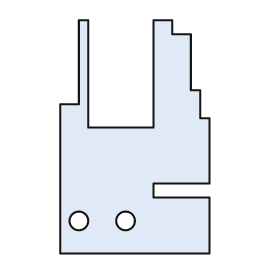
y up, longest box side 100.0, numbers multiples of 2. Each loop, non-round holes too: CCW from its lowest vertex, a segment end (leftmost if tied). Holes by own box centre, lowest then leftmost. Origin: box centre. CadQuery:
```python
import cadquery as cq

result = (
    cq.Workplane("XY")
    .moveTo(-32.0, -50.0)
    .lineTo(32.0, -50.0)
    .lineTo(32.0, -26.0)
    .lineTo(8.0, -26.0)
    .lineTo(8.0, -20.0)
    .lineTo(32.0, -20.0)
    .lineTo(32.0, 8.0)
    .lineTo(28.0, 8.0)
    .lineTo(28.0, 20.0)
    .lineTo(24.0, 20.0)
    .lineTo(24.0, 44.0)
    .lineTo(16.0, 44.0)
    .lineTo(16.0, 50.0)
    .lineTo(8.0, 50.0)
    .lineTo(8.0, 4.0)
    .lineTo(-20.0, 4.0)
    .lineTo(-20.0, 50.0)
    .lineTo(-24.0, 50.0)
    .lineTo(-24.0, 14.0)
    .lineTo(-32.0, 14.0)
    .close()
    .moveTo(-24.0, -36.0)
    .circle(4.0)
    .moveTo(-4.0, -36.0)
    .circle(4.0)
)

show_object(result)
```